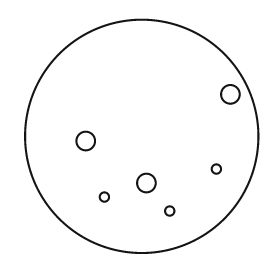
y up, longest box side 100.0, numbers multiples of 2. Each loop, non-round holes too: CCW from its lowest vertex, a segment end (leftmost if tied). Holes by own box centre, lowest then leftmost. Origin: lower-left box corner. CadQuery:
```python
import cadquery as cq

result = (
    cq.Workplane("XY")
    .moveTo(50.0, 50.0)
    .circle(50.0)
    .moveTo(62.0, 18.0)
    .circle(2.0)
    .moveTo(34.0, 24.0)
    .circle(2.0)
    .moveTo(52.0, 30.0)
    .circle(4.0)
    .moveTo(82.0, 36.0)
    .circle(2.0)
    .moveTo(26.0, 48.0)
    .circle(4.0)
    .moveTo(88.0, 68.0)
    .circle(4.0)
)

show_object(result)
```